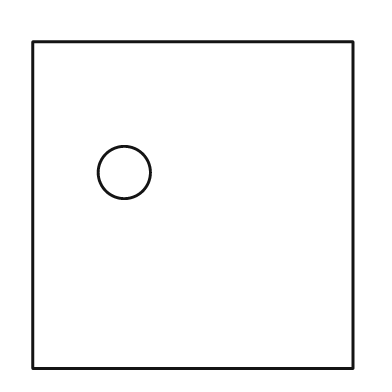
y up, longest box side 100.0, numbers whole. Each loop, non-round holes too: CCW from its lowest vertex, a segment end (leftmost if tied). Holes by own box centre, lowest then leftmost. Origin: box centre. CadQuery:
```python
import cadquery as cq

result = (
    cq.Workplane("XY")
    .moveTo(-49.0, -50.0)
    .lineTo(49.0, -50.0)
    .lineTo(49.0, 50.0)
    .lineTo(-49.0, 50.0)
    .close()
    .moveTo(-21.0, 10.0)
    .circle(8.0)
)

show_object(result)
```